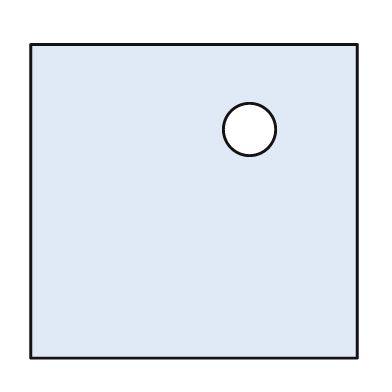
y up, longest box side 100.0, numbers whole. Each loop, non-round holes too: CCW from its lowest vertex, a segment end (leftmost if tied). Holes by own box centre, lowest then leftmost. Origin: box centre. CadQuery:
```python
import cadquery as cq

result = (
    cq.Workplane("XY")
    .moveTo(-50.0, -48.0)
    .lineTo(50.0, -48.0)
    .lineTo(50.0, 48.0)
    .lineTo(-50.0, 48.0)
    .close()
    .moveTo(17.0, 22.0)
    .circle(8.0)
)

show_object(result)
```